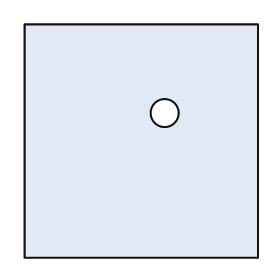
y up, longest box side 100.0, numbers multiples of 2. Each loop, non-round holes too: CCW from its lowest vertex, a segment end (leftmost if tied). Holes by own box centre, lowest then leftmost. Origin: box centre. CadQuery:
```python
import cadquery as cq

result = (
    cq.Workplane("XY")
    .moveTo(-50.0, -50.0)
    .lineTo(50.0, -50.0)
    .lineTo(50.0, 50.0)
    .lineTo(-50.0, 50.0)
    .close()
    .moveTo(10.0, 12.0)
    .circle(6.0)
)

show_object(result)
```